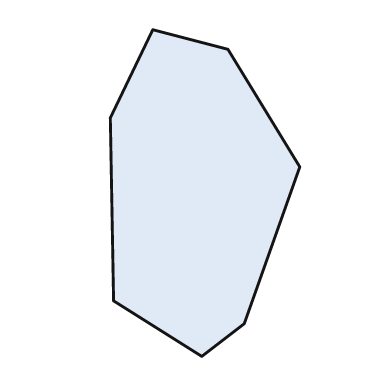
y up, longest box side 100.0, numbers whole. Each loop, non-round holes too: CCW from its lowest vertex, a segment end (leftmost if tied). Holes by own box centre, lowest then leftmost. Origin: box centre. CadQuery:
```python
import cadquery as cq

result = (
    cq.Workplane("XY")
    .moveTo(-1.0, -50.0)
    .lineTo(12.0, -40.0)
    .lineTo(29.0, 8.0)
    .lineTo(7.0, 44.0)
    .lineTo(-16.0, 50.0)
    .lineTo(-29.0, 23.0)
    .lineTo(-28.0, -33.0)
    .close()
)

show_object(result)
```